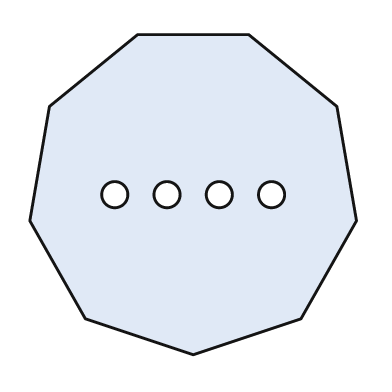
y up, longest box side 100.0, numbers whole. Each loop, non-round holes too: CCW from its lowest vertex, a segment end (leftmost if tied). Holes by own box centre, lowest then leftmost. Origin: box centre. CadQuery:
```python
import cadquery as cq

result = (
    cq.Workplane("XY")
    .moveTo(0.0, -49.0)
    .lineTo(33.0, -38.0)
    .lineTo(50.0, -8.0)
    .lineTo(44.0, 27.0)
    .lineTo(17.0, 49.0)
    .lineTo(-17.0, 49.0)
    .lineTo(-44.0, 27.0)
    .lineTo(-50.0, -8.0)
    .lineTo(-33.0, -38.0)
    .close()
    .moveTo(-24.0, 0.0)
    .circle(4.0)
    .moveTo(-8.0, 0.0)
    .circle(4.0)
    .moveTo(8.0, 0.0)
    .circle(4.0)
    .moveTo(24.0, 0.0)
    .circle(4.0)
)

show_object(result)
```